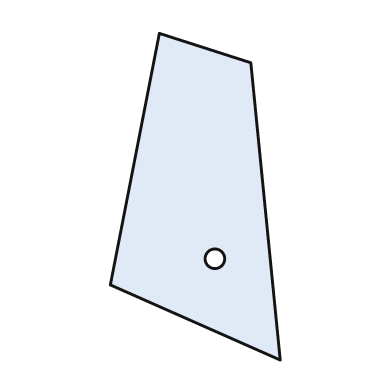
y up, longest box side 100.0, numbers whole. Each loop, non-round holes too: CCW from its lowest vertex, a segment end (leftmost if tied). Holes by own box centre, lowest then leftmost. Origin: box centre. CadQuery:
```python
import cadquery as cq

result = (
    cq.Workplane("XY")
    .moveTo(26.0, -50.0)
    .lineTo(17.0, 41.0)
    .lineTo(-11.0, 50.0)
    .lineTo(-26.0, -27.0)
    .close()
    .moveTo(6.0, -19.0)
    .circle(3.0)
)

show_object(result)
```